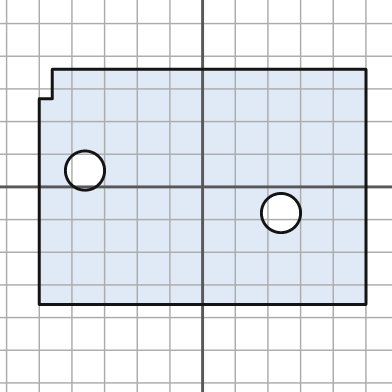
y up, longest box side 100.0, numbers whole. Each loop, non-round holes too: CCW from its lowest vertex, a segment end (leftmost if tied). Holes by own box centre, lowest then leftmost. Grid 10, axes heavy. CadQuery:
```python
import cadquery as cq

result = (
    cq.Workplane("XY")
    .moveTo(-50.0, -36.0)
    .lineTo(50.0, -36.0)
    .lineTo(50.0, 36.0)
    .lineTo(-46.0, 36.0)
    .lineTo(-46.0, 27.0)
    .lineTo(-50.0, 27.0)
    .close()
    .moveTo(24.0, -8.0)
    .circle(6.0)
    .moveTo(-36.0, 5.0)
    .circle(6.0)
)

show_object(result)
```